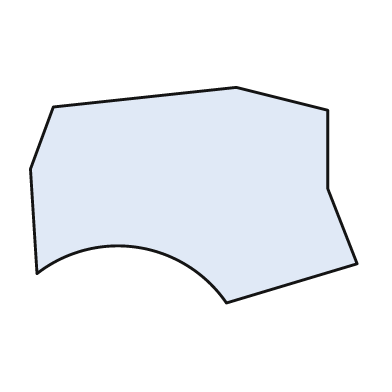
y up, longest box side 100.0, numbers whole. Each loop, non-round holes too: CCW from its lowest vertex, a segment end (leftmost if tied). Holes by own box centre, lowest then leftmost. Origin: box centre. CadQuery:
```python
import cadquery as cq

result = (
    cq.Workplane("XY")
    .moveTo(10.0, -33.0)
    .lineTo(50.0, -21.0)
    .lineTo(41.0, 2.0)
    .lineTo(41.0, 26.0)
    .lineTo(13.0, 33.0)
    .lineTo(-43.0, 27.0)
    .lineTo(-50.0, 8.0)
    .lineTo(-48.0, -24.0)
    .threePointArc((-17.0, -16.0), (10.0, -33.0))
    .close()
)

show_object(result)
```